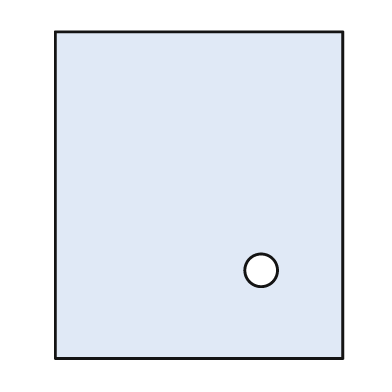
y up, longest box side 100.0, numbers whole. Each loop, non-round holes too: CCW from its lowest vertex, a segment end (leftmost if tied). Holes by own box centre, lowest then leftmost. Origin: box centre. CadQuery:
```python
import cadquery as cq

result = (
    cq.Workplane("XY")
    .moveTo(-44.0, -50.0)
    .lineTo(44.0, -50.0)
    .lineTo(44.0, 50.0)
    .lineTo(-44.0, 50.0)
    .close()
    .moveTo(19.0, -23.0)
    .circle(5.0)
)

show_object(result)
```